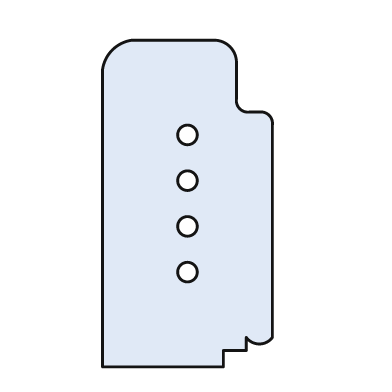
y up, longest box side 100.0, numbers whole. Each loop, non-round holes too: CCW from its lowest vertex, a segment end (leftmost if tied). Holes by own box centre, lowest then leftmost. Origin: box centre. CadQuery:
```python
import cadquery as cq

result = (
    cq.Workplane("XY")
    .moveTo(-26.0, -50.0)
    .lineTo(11.0, -50.0)
    .lineTo(11.0, -45.0)
    .lineTo(18.0, -45.0)
    .lineTo(18.0, -41.0)
    .threePointArc((22.0, -43.0), (26.0, -41.0))
    .lineTo(26.0, 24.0)
    .threePointArc((25.0, 27.0), (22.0, 28.0))
    .lineTo(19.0, 28.0)
    .threePointArc((16.0, 29.0), (15.0, 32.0))
    .lineTo(15.0, 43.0)
    .threePointArc((13.0, 48.0), (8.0, 50.0))
    .lineTo(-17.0, 50.0)
    .threePointArc((-23.0, 47.0), (-26.0, 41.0))
    .close()
    .moveTo(0.0, -21.0)
    .circle(3.0)
    .moveTo(0.0, -7.0)
    .circle(3.0)
    .moveTo(0.0, 7.0)
    .circle(3.0)
    .moveTo(0.0, 21.0)
    .circle(3.0)
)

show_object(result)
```